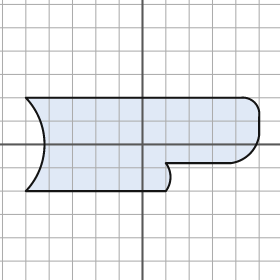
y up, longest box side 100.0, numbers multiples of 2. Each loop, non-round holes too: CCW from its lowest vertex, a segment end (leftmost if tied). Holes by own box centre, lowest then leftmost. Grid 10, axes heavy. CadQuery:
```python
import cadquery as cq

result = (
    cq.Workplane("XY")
    .moveTo(-50.0, -20.0)
    .lineTo(10.0, -20.0)
    .threePointArc((12.0, -14.0), (10.0, -8.0))
    .lineTo(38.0, -8.0)
    .threePointArc((46.0, -4.0), (50.0, 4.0))
    .lineTo(50.0, 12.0)
    .threePointArc((48.0, 18.0), (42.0, 20.0))
    .lineTo(-50.0, 20.0)
    .threePointArc((-42.0, 0.0), (-50.0, -20.0))
    .close()
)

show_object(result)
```